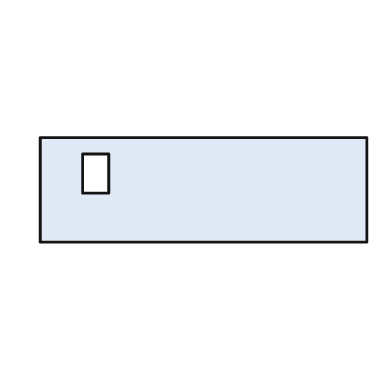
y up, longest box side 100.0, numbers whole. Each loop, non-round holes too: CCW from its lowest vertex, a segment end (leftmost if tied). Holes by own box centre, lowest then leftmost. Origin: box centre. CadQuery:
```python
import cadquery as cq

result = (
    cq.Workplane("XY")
    .moveTo(-50.0, -16.0)
    .lineTo(50.0, -16.0)
    .lineTo(50.0, 16.0)
    .lineTo(-50.0, 16.0)
    .close()
    .moveTo(-37.0, -1.0)
    .lineTo(-29.0, -1.0)
    .lineTo(-29.0, 11.0)
    .lineTo(-37.0, 11.0)
    .close()
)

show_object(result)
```